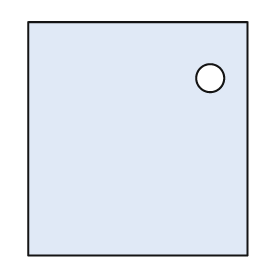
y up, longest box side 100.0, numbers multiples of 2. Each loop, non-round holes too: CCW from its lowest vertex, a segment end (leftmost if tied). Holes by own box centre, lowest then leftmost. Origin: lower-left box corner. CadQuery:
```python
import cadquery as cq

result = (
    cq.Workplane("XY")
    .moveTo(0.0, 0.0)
    .lineTo(94.0, 0.0)
    .lineTo(94.0, 100.0)
    .lineTo(0.0, 100.0)
    .close()
    .moveTo(78.0, 76.0)
    .circle(6.0)
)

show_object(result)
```